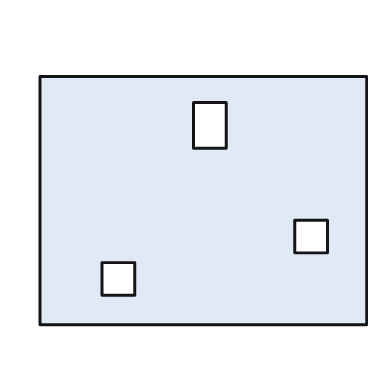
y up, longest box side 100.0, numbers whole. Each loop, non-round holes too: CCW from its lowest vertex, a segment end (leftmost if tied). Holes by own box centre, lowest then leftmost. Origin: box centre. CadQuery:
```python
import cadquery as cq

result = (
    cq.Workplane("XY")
    .moveTo(-50.0, -38.0)
    .lineTo(50.0, -38.0)
    .lineTo(50.0, 38.0)
    .lineTo(-50.0, 38.0)
    .close()
    .moveTo(-31.0, -29.0)
    .lineTo(-21.0, -29.0)
    .lineTo(-21.0, -19.0)
    .lineTo(-31.0, -19.0)
    .close()
    .moveTo(28.0, -16.0)
    .lineTo(38.0, -16.0)
    .lineTo(38.0, -6.0)
    .lineTo(28.0, -6.0)
    .close()
    .moveTo(-3.0, 16.0)
    .lineTo(7.0, 16.0)
    .lineTo(7.0, 30.0)
    .lineTo(-3.0, 30.0)
    .close()
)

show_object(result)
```